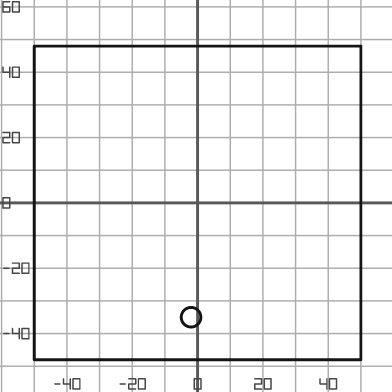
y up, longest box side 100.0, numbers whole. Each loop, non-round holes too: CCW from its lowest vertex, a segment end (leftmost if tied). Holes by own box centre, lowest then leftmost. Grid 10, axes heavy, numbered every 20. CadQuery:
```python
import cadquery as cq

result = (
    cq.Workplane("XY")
    .moveTo(-50.0, -48.0)
    .lineTo(50.0, -48.0)
    .lineTo(50.0, 48.0)
    .lineTo(-50.0, 48.0)
    .close()
    .moveTo(-2.0, -35.0)
    .circle(3.0)
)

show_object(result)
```